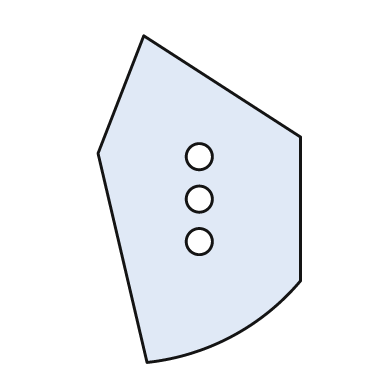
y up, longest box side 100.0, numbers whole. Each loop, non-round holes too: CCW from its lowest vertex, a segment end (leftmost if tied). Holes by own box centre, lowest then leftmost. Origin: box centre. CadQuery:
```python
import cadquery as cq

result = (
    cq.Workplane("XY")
    .moveTo(-16.0, -50.0)
    .threePointArc((10.0, -42.0), (31.0, -25.0))
    .lineTo(31.0, 19.0)
    .lineTo(-17.0, 50.0)
    .lineTo(-31.0, 14.0)
    .close()
    .moveTo(0.0, -13.0)
    .circle(4.0)
    .moveTo(0.0, 0.0)
    .circle(4.0)
    .moveTo(0.0, 13.0)
    .circle(4.0)
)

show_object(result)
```